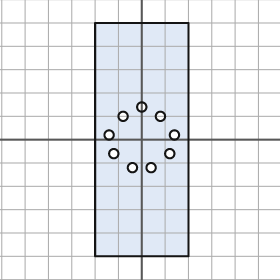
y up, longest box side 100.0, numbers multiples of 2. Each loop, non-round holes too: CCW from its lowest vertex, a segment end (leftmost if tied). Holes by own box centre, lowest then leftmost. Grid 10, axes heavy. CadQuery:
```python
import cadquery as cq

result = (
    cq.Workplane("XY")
    .moveTo(-20.0, -50.0)
    .lineTo(20.0, -50.0)
    .lineTo(20.0, 50.0)
    .lineTo(-20.0, 50.0)
    .close()
    .moveTo(-4.0, -12.0)
    .circle(2.0)
    .moveTo(4.0, -12.0)
    .circle(2.0)
    .moveTo(-12.0, -6.0)
    .circle(2.0)
    .moveTo(12.0, -6.0)
    .circle(2.0)
    .moveTo(-14.0, 2.0)
    .circle(2.0)
    .moveTo(14.0, 2.0)
    .circle(2.0)
    .moveTo(-8.0, 10.0)
    .circle(2.0)
    .moveTo(8.0, 10.0)
    .circle(2.0)
    .moveTo(0.0, 14.0)
    .circle(2.0)
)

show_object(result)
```